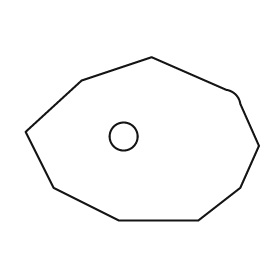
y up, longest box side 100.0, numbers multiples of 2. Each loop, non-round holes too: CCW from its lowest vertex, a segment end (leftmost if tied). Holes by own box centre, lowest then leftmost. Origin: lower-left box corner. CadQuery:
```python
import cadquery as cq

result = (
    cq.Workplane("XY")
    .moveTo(40.0, 0.0)
    .lineTo(74.0, 0.0)
    .lineTo(92.0, 14.0)
    .lineTo(100.0, 32.0)
    .lineTo(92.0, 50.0)
    .threePointArc((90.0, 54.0), (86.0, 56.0))
    .lineTo(54.0, 70.0)
    .lineTo(24.0, 60.0)
    .lineTo(0.0, 38.0)
    .lineTo(12.0, 14.0)
    .close()
    .moveTo(42.0, 36.0)
    .circle(6.0)
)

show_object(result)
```